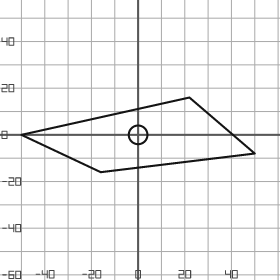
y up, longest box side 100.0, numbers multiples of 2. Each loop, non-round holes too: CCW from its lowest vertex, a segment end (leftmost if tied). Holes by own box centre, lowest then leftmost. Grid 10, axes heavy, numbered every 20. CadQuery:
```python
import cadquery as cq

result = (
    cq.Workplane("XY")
    .moveTo(-16.0, -16.0)
    .lineTo(50.0, -8.0)
    .lineTo(22.0, 16.0)
    .lineTo(-50.0, 0.0)
    .close()
    .moveTo(0.0, 0.0)
    .circle(4.0)
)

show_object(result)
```